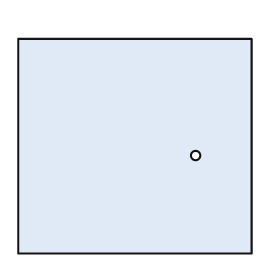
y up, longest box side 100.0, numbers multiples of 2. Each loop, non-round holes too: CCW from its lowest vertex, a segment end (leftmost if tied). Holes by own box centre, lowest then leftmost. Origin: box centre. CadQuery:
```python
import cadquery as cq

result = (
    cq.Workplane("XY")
    .moveTo(-50.0, -46.0)
    .lineTo(50.0, -46.0)
    .lineTo(50.0, 46.0)
    .lineTo(-50.0, 46.0)
    .close()
    .moveTo(26.0, -4.0)
    .circle(2.0)
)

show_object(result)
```